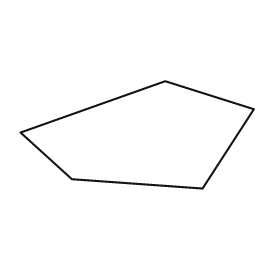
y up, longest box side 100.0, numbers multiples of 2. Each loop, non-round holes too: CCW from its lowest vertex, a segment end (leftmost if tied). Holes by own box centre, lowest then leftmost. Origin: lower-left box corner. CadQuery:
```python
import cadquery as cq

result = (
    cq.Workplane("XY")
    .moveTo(78.0, 0.0)
    .lineTo(100.0, 34.0)
    .lineTo(62.0, 46.0)
    .lineTo(0.0, 24.0)
    .lineTo(22.0, 4.0)
    .close()
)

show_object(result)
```